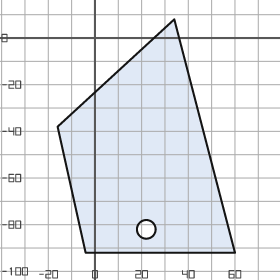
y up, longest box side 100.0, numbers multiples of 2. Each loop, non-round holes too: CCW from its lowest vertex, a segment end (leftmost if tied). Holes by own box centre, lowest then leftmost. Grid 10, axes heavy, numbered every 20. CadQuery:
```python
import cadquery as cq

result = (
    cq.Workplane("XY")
    .moveTo(-4.0, -92.0)
    .lineTo(60.0, -92.0)
    .lineTo(34.0, 8.0)
    .lineTo(-16.0, -38.0)
    .close()
    .moveTo(22.0, -82.0)
    .circle(4.0)
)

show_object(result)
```